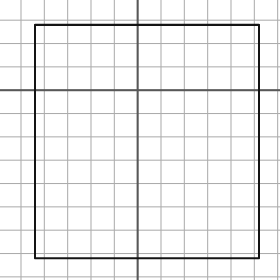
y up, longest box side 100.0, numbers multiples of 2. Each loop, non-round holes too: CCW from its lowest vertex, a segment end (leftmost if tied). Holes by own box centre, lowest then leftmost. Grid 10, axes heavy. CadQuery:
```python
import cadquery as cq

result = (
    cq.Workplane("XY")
    .moveTo(-44.0, -72.0)
    .lineTo(52.0, -72.0)
    .lineTo(52.0, 28.0)
    .lineTo(-44.0, 28.0)
    .close()
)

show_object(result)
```